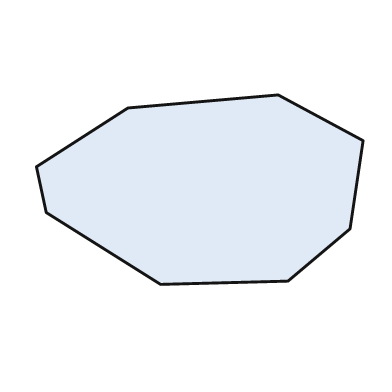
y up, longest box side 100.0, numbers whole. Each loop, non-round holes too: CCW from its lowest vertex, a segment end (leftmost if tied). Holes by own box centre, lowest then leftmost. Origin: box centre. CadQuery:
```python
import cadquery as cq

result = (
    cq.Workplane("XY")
    .moveTo(-12.0, -29.0)
    .lineTo(27.0, -28.0)
    .lineTo(46.0, -12.0)
    .lineTo(50.0, 15.0)
    .lineTo(24.0, 29.0)
    .lineTo(-22.0, 25.0)
    .lineTo(-50.0, 7.0)
    .lineTo(-47.0, -7.0)
    .close()
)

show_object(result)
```